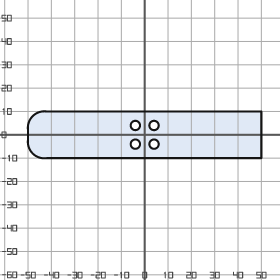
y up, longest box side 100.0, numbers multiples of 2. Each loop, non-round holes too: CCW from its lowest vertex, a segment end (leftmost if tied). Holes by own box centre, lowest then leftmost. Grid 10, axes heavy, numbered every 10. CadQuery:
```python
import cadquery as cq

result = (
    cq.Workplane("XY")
    .moveTo(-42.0, -10.0)
    .lineTo(50.0, -10.0)
    .lineTo(50.0, 10.0)
    .lineTo(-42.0, 10.0)
    .threePointArc((-48.0, 8.0), (-50.0, 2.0))
    .lineTo(-50.0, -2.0)
    .threePointArc((-48.0, -8.0), (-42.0, -10.0))
    .close()
    .moveTo(-4.0, -4.0)
    .circle(2.0)
    .moveTo(4.0, -4.0)
    .circle(2.0)
    .moveTo(-4.0, 4.0)
    .circle(2.0)
    .moveTo(4.0, 4.0)
    .circle(2.0)
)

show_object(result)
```